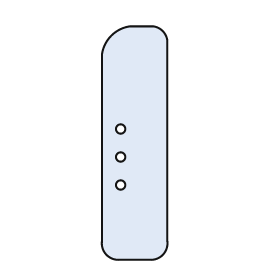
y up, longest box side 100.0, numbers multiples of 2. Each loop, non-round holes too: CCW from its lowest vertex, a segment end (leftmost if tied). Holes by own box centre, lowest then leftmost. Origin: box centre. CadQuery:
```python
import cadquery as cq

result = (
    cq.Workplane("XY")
    .moveTo(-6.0, -50.0)
    .lineTo(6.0, -50.0)
    .threePointArc((12.0, -48.0), (14.0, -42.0))
    .lineTo(14.0, 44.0)
    .threePointArc((12.0, 48.0), (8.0, 50.0))
    .lineTo(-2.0, 50.0)
    .threePointArc((-10.0, 46.0), (-14.0, 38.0))
    .lineTo(-14.0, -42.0)
    .threePointArc((-12.0, -48.0), (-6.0, -50.0))
    .close()
    .moveTo(-6.0, -18.0)
    .circle(2.0)
    .moveTo(-6.0, -6.0)
    .circle(2.0)
    .moveTo(-6.0, 6.0)
    .circle(2.0)
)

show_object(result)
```